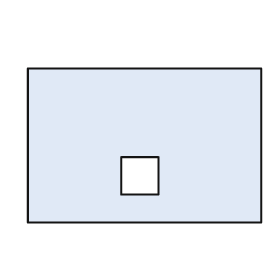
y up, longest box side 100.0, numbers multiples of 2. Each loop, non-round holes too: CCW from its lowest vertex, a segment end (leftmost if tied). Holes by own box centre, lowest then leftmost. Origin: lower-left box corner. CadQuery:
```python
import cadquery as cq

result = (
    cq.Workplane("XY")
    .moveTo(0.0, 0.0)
    .lineTo(100.0, 0.0)
    .lineTo(100.0, 66.0)
    .lineTo(0.0, 66.0)
    .close()
    .moveTo(40.0, 12.0)
    .lineTo(56.0, 12.0)
    .lineTo(56.0, 28.0)
    .lineTo(40.0, 28.0)
    .close()
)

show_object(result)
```